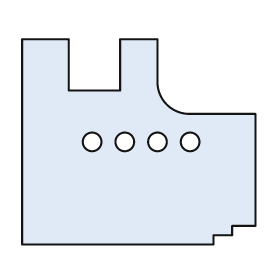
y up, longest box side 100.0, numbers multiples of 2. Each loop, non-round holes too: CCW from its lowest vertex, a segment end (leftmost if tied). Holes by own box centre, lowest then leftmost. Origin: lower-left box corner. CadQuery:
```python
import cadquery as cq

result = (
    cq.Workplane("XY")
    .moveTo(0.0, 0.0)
    .lineTo(82.0, 0.0)
    .lineTo(82.0, 4.0)
    .lineTo(90.0, 4.0)
    .lineTo(90.0, 8.0)
    .lineTo(100.0, 8.0)
    .lineTo(100.0, 56.0)
    .lineTo(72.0, 56.0)
    .threePointArc((62.0, 60.0), (58.0, 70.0))
    .lineTo(58.0, 88.0)
    .lineTo(42.0, 88.0)
    .lineTo(42.0, 66.0)
    .lineTo(20.0, 66.0)
    .lineTo(20.0, 88.0)
    .lineTo(0.0, 88.0)
    .close()
    .moveTo(30.0, 44.0)
    .circle(4.0)
    .moveTo(44.0, 44.0)
    .circle(4.0)
    .moveTo(58.0, 44.0)
    .circle(4.0)
    .moveTo(72.0, 44.0)
    .circle(4.0)
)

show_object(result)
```